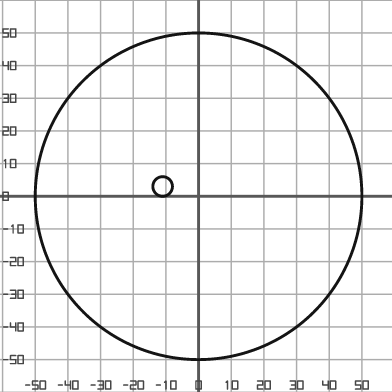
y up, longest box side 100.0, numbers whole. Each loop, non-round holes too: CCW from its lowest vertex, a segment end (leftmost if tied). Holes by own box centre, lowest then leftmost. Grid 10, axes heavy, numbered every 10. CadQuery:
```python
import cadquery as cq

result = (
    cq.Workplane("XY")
    .moveTo(0.0, 0.0)
    .circle(50.0)
    .moveTo(-11.0, 3.0)
    .circle(3.0)
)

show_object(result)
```